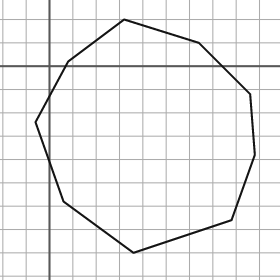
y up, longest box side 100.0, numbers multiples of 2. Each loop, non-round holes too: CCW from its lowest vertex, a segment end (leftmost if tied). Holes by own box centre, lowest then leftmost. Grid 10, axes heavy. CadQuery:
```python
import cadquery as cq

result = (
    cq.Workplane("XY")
    .moveTo(36.0, -80.0)
    .lineTo(78.0, -66.0)
    .lineTo(88.0, -38.0)
    .lineTo(86.0, -12.0)
    .lineTo(64.0, 10.0)
    .lineTo(32.0, 20.0)
    .lineTo(8.0, 2.0)
    .lineTo(-6.0, -24.0)
    .lineTo(6.0, -58.0)
    .close()
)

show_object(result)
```